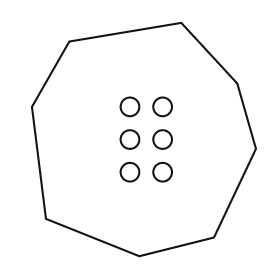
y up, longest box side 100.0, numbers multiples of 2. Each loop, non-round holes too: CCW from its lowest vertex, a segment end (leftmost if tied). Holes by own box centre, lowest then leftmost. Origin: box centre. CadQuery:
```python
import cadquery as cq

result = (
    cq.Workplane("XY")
    .moveTo(-2.0, -50.0)
    .lineTo(30.0, -42.0)
    .lineTo(48.0, -4.0)
    .lineTo(40.0, 24.0)
    .lineTo(16.0, 50.0)
    .lineTo(-32.0, 42.0)
    .lineTo(-48.0, 14.0)
    .lineTo(-42.0, -34.0)
    .close()
    .moveTo(-6.0, -14.0)
    .circle(4.0)
    .moveTo(8.0, -14.0)
    .circle(4.0)
    .moveTo(-6.0, 0.0)
    .circle(4.0)
    .moveTo(8.0, 0.0)
    .circle(4.0)
    .moveTo(-6.0, 14.0)
    .circle(4.0)
    .moveTo(8.0, 14.0)
    .circle(4.0)
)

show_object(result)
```